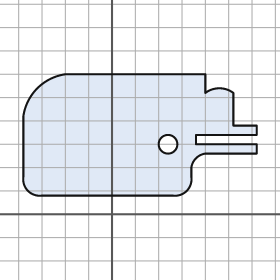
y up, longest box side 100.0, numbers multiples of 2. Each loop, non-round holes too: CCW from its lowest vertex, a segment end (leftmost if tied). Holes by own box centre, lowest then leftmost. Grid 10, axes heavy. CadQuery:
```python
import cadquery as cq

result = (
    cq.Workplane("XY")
    .moveTo(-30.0, 8.0)
    .lineTo(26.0, 8.0)
    .threePointArc((32.0, 10.0), (34.0, 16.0))
    .lineTo(34.0, 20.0)
    .threePointArc((36.0, 24.0), (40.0, 26.0))
    .lineTo(62.0, 26.0)
    .lineTo(62.0, 30.0)
    .lineTo(36.0, 30.0)
    .lineTo(36.0, 34.0)
    .lineTo(62.0, 34.0)
    .lineTo(62.0, 38.0)
    .lineTo(52.0, 38.0)
    .lineTo(52.0, 52.0)
    .threePointArc((46.0, 54.0), (40.0, 52.0))
    .lineTo(40.0, 60.0)
    .lineTo(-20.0, 60.0)
    .threePointArc((-32.0, 54.0), (-38.0, 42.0))
    .lineTo(-38.0, 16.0)
    .threePointArc((-36.0, 10.0), (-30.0, 8.0))
    .close()
    .moveTo(24.0, 30.0)
    .circle(4.0)
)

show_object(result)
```